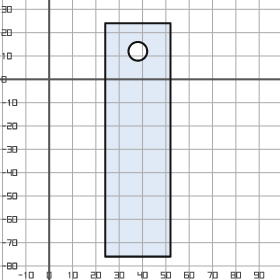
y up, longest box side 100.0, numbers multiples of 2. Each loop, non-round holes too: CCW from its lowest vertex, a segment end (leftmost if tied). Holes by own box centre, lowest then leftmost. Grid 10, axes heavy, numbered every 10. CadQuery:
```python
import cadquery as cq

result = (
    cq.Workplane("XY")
    .moveTo(24.0, -76.0)
    .lineTo(52.0, -76.0)
    .lineTo(52.0, 24.0)
    .lineTo(24.0, 24.0)
    .close()
    .moveTo(38.0, 12.0)
    .circle(4.0)
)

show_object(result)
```